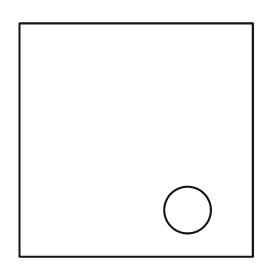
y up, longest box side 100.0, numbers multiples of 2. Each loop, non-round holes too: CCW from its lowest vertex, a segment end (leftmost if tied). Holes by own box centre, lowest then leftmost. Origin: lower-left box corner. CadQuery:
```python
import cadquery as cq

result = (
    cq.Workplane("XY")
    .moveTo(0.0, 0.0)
    .lineTo(100.0, 0.0)
    .lineTo(100.0, 100.0)
    .lineTo(0.0, 100.0)
    .close()
    .moveTo(72.0, 20.0)
    .circle(10.0)
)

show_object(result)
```